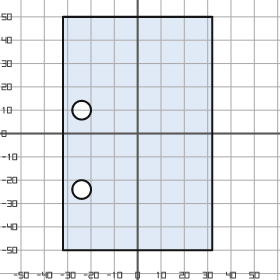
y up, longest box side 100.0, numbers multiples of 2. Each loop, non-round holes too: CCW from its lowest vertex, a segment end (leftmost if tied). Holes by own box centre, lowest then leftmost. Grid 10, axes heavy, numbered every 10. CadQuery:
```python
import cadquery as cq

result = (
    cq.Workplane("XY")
    .moveTo(-32.0, -50.0)
    .lineTo(32.0, -50.0)
    .lineTo(32.0, 50.0)
    .lineTo(-32.0, 50.0)
    .close()
    .moveTo(-24.0, -24.0)
    .circle(4.0)
    .moveTo(-24.0, 10.0)
    .circle(4.0)
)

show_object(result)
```